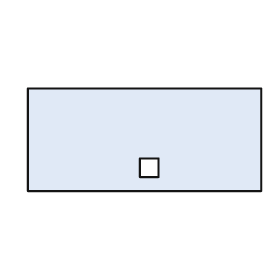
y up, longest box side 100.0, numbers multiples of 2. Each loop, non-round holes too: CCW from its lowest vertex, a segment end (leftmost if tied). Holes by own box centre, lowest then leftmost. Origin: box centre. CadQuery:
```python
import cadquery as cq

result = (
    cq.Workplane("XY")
    .moveTo(-50.0, -22.0)
    .lineTo(50.0, -22.0)
    .lineTo(50.0, 22.0)
    .lineTo(-50.0, 22.0)
    .close()
    .moveTo(-2.0, -16.0)
    .lineTo(6.0, -16.0)
    .lineTo(6.0, -8.0)
    .lineTo(-2.0, -8.0)
    .close()
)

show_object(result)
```